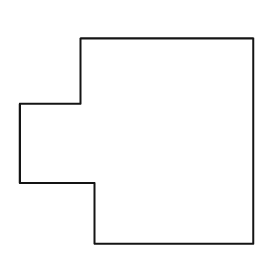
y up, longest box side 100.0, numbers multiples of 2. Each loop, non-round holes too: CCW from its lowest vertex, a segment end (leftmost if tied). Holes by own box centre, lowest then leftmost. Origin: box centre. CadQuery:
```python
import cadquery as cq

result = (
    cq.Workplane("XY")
    .moveTo(-18.0, -44.0)
    .lineTo(50.0, -44.0)
    .lineTo(50.0, 44.0)
    .lineTo(-24.0, 44.0)
    .lineTo(-24.0, 16.0)
    .lineTo(-50.0, 16.0)
    .lineTo(-50.0, -18.0)
    .lineTo(-18.0, -18.0)
    .close()
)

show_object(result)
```